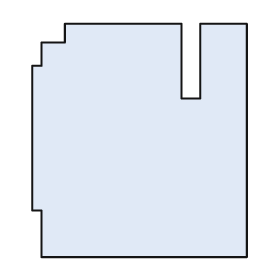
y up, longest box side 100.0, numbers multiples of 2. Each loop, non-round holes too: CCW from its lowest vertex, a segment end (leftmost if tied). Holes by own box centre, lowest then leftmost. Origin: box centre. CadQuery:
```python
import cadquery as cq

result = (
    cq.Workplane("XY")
    .moveTo(-42.0, -50.0)
    .lineTo(46.0, -50.0)
    .lineTo(46.0, 50.0)
    .lineTo(26.0, 50.0)
    .lineTo(26.0, 18.0)
    .lineTo(18.0, 18.0)
    .lineTo(18.0, 50.0)
    .lineTo(-32.0, 50.0)
    .lineTo(-32.0, 42.0)
    .lineTo(-42.0, 42.0)
    .lineTo(-42.0, 32.0)
    .lineTo(-46.0, 32.0)
    .lineTo(-46.0, -30.0)
    .lineTo(-42.0, -30.0)
    .close()
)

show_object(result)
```